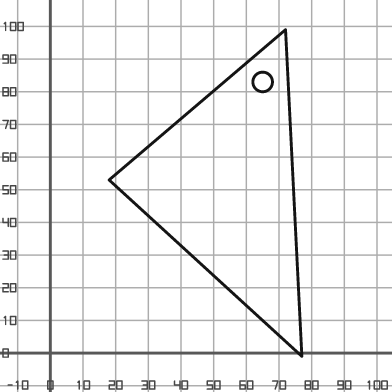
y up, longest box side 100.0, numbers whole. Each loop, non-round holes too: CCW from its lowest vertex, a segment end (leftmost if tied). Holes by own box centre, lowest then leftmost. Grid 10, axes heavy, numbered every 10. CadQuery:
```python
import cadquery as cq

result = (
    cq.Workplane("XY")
    .moveTo(77.0, -1.0)
    .lineTo(72.0, 99.0)
    .lineTo(18.0, 53.0)
    .close()
    .moveTo(65.0, 83.0)
    .circle(3.0)
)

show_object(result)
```